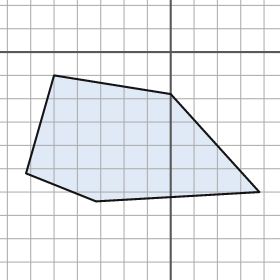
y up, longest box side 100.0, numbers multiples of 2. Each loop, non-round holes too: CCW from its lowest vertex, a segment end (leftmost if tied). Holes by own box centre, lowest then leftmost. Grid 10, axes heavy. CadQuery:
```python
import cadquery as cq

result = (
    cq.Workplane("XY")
    .moveTo(-32.0, -64.0)
    .lineTo(38.0, -60.0)
    .lineTo(0.0, -18.0)
    .lineTo(-50.0, -10.0)
    .lineTo(-62.0, -52.0)
    .close()
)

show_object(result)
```